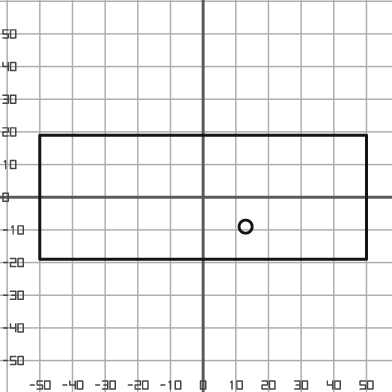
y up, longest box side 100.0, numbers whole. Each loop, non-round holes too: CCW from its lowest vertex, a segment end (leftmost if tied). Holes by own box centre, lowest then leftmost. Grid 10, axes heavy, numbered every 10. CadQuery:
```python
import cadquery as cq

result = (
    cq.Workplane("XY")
    .moveTo(-50.0, -19.0)
    .lineTo(50.0, -19.0)
    .lineTo(50.0, 19.0)
    .lineTo(-50.0, 19.0)
    .close()
    .moveTo(13.0, -9.0)
    .circle(2.0)
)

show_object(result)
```